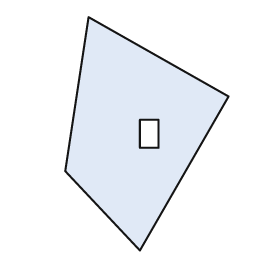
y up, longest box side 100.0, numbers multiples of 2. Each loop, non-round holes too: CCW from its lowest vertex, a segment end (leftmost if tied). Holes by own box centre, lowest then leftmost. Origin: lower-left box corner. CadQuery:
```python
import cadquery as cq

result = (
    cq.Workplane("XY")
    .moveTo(32.0, 0.0)
    .lineTo(70.0, 66.0)
    .lineTo(10.0, 100.0)
    .lineTo(0.0, 34.0)
    .close()
    .moveTo(32.0, 44.0)
    .lineTo(40.0, 44.0)
    .lineTo(40.0, 56.0)
    .lineTo(32.0, 56.0)
    .close()
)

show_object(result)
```